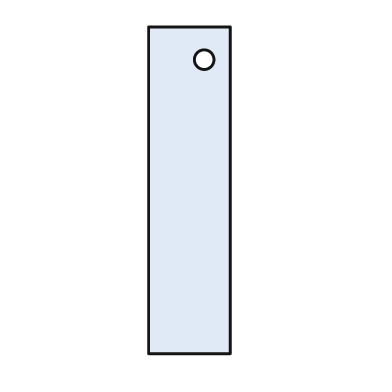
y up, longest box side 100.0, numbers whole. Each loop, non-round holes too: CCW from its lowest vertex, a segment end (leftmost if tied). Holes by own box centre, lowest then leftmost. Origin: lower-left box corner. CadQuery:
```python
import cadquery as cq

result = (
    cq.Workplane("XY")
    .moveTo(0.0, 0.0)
    .lineTo(25.0, 0.0)
    .lineTo(25.0, 100.0)
    .lineTo(0.0, 100.0)
    .close()
    .moveTo(17.0, 90.0)
    .circle(3.0)
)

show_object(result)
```